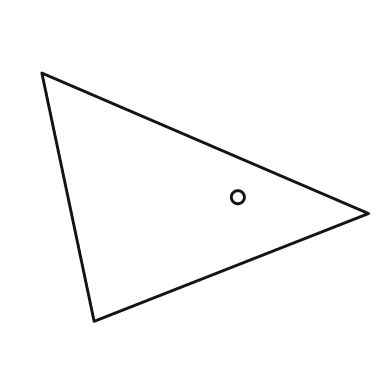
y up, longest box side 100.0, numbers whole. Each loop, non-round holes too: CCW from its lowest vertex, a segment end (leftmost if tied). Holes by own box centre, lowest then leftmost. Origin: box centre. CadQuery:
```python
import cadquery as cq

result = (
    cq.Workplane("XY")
    .moveTo(-34.0, -38.0)
    .lineTo(50.0, -5.0)
    .lineTo(-50.0, 38.0)
    .close()
    .moveTo(10.0, 0.0)
    .circle(2.0)
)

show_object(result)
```